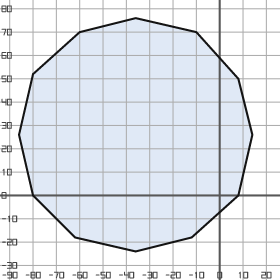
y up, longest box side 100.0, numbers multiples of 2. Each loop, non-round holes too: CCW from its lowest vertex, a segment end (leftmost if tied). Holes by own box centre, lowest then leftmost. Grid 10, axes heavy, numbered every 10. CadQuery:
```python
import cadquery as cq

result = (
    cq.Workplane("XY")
    .moveTo(-36.0, -24.0)
    .lineTo(-12.0, -18.0)
    .lineTo(8.0, 0.0)
    .lineTo(14.0, 26.0)
    .lineTo(8.0, 50.0)
    .lineTo(-10.0, 70.0)
    .lineTo(-36.0, 76.0)
    .lineTo(-60.0, 70.0)
    .lineTo(-80.0, 52.0)
    .lineTo(-86.0, 26.0)
    .lineTo(-80.0, 0.0)
    .lineTo(-62.0, -18.0)
    .close()
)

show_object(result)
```